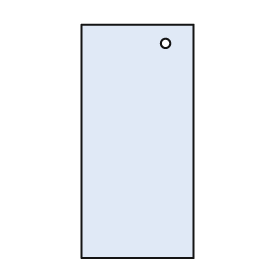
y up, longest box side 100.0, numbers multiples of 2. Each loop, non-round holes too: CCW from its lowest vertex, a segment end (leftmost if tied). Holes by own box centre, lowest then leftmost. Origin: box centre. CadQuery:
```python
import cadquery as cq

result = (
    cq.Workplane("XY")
    .moveTo(-24.0, -50.0)
    .lineTo(24.0, -50.0)
    .lineTo(24.0, 50.0)
    .lineTo(-24.0, 50.0)
    .close()
    .moveTo(12.0, 42.0)
    .circle(2.0)
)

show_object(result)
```